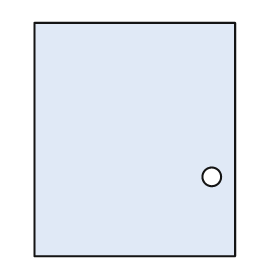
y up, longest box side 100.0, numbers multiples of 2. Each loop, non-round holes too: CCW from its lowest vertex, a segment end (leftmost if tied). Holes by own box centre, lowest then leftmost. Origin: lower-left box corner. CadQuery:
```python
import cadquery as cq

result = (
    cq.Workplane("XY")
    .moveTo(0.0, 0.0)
    .lineTo(86.0, 0.0)
    .lineTo(86.0, 100.0)
    .lineTo(0.0, 100.0)
    .close()
    .moveTo(76.0, 34.0)
    .circle(4.0)
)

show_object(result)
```